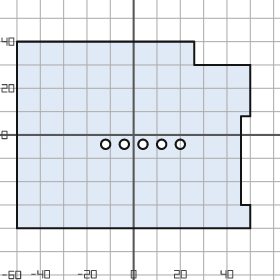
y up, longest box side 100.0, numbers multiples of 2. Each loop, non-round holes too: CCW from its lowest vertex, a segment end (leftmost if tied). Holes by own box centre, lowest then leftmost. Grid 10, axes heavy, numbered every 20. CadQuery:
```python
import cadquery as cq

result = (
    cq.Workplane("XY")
    .moveTo(-50.0, -40.0)
    .lineTo(50.0, -40.0)
    .lineTo(50.0, -30.0)
    .lineTo(46.0, -30.0)
    .lineTo(46.0, 8.0)
    .lineTo(50.0, 8.0)
    .lineTo(50.0, 30.0)
    .lineTo(26.0, 30.0)
    .lineTo(26.0, 40.0)
    .lineTo(-50.0, 40.0)
    .close()
    .moveTo(-12.0, -4.0)
    .circle(2.0)
    .moveTo(-4.0, -4.0)
    .circle(2.0)
    .moveTo(4.0, -4.0)
    .circle(2.0)
    .moveTo(12.0, -4.0)
    .circle(2.0)
    .moveTo(20.0, -4.0)
    .circle(2.0)
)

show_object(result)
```